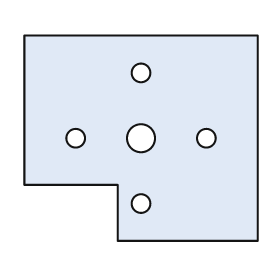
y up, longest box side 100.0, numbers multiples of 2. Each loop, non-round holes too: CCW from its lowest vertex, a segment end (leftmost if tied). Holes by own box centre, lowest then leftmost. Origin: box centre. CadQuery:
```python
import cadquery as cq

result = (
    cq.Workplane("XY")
    .moveTo(-10.0, -44.0)
    .lineTo(50.0, -44.0)
    .lineTo(50.0, 44.0)
    .lineTo(-50.0, 44.0)
    .lineTo(-50.0, -20.0)
    .lineTo(-10.0, -20.0)
    .close()
    .moveTo(0.0, -28.0)
    .circle(4.0)
    .moveTo(-28.0, 0.0)
    .circle(4.0)
    .moveTo(0.0, 0.0)
    .circle(6.0)
    .moveTo(28.0, 0.0)
    .circle(4.0)
    .moveTo(0.0, 28.0)
    .circle(4.0)
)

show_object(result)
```